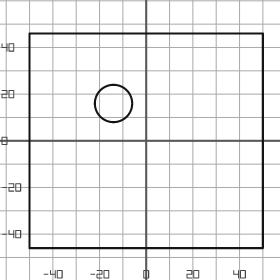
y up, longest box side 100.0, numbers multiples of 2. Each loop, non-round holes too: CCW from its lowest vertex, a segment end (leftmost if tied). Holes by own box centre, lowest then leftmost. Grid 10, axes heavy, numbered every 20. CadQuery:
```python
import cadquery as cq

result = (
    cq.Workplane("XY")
    .moveTo(-50.0, -46.0)
    .lineTo(50.0, -46.0)
    .lineTo(50.0, 46.0)
    .lineTo(-50.0, 46.0)
    .close()
    .moveTo(-14.0, 16.0)
    .circle(8.0)
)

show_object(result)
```